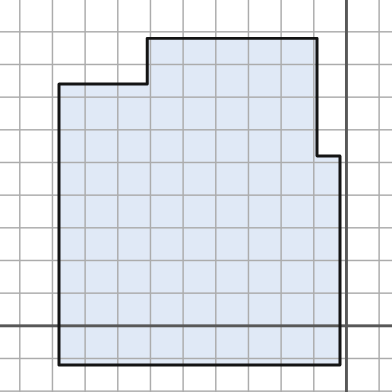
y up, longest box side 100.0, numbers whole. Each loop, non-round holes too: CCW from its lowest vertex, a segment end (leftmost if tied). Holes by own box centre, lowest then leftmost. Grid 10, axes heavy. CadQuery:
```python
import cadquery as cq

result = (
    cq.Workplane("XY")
    .moveTo(-88.0, -12.0)
    .lineTo(-2.0, -12.0)
    .lineTo(-2.0, 52.0)
    .lineTo(-9.0, 52.0)
    .lineTo(-9.0, 88.0)
    .lineTo(-61.0, 88.0)
    .lineTo(-61.0, 74.0)
    .lineTo(-88.0, 74.0)
    .close()
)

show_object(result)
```